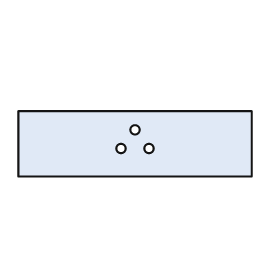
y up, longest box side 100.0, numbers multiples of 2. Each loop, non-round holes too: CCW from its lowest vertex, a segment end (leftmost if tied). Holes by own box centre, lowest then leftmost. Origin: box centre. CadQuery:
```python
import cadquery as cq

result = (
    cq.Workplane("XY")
    .moveTo(-50.0, -14.0)
    .lineTo(50.0, -14.0)
    .lineTo(50.0, 14.0)
    .lineTo(-50.0, 14.0)
    .close()
    .moveTo(-6.0, -2.0)
    .circle(2.0)
    .moveTo(6.0, -2.0)
    .circle(2.0)
    .moveTo(0.0, 6.0)
    .circle(2.0)
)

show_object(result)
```